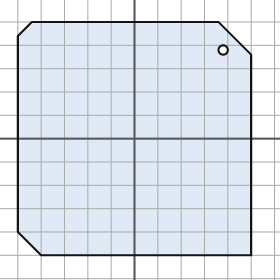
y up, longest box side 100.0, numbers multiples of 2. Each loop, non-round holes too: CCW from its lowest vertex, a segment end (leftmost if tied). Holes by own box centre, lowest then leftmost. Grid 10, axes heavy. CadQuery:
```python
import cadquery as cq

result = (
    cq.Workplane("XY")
    .moveTo(-40.0, -50.0)
    .lineTo(50.0, -50.0)
    .lineTo(50.0, 36.0)
    .lineTo(36.0, 50.0)
    .lineTo(-44.0, 50.0)
    .lineTo(-50.0, 44.0)
    .lineTo(-50.0, -40.0)
    .close()
    .moveTo(38.0, 38.0)
    .circle(2.0)
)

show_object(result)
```